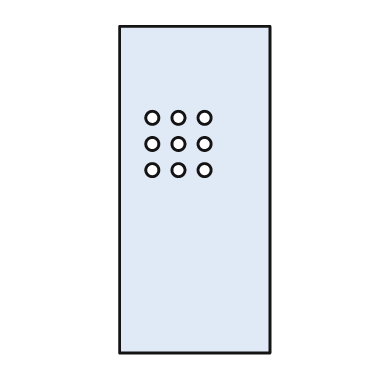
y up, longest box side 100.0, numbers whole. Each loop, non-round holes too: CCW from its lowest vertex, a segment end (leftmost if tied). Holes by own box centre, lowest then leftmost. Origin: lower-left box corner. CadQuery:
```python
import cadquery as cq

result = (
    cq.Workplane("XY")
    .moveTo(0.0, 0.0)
    .lineTo(46.0, 0.0)
    .lineTo(46.0, 100.0)
    .lineTo(0.0, 100.0)
    .close()
    .moveTo(10.0, 56.0)
    .circle(2.0)
    .moveTo(18.0, 56.0)
    .circle(2.0)
    .moveTo(26.0, 56.0)
    .circle(2.0)
    .moveTo(10.0, 64.0)
    .circle(2.0)
    .moveTo(18.0, 64.0)
    .circle(2.0)
    .moveTo(26.0, 64.0)
    .circle(2.0)
    .moveTo(10.0, 72.0)
    .circle(2.0)
    .moveTo(18.0, 72.0)
    .circle(2.0)
    .moveTo(26.0, 72.0)
    .circle(2.0)
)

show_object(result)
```